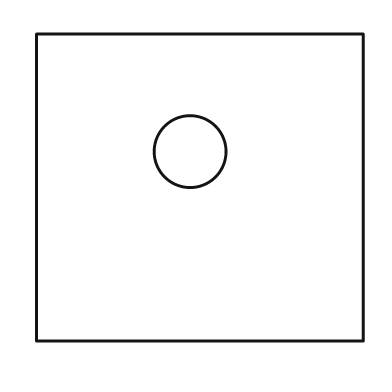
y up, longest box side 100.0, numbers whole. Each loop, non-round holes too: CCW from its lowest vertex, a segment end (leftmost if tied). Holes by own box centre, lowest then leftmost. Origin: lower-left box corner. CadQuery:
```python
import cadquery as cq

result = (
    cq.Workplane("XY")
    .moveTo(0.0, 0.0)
    .lineTo(100.0, 0.0)
    .lineTo(100.0, 94.0)
    .lineTo(0.0, 94.0)
    .close()
    .moveTo(47.0, 58.0)
    .circle(11.0)
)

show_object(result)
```